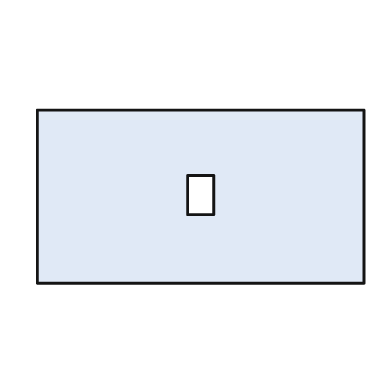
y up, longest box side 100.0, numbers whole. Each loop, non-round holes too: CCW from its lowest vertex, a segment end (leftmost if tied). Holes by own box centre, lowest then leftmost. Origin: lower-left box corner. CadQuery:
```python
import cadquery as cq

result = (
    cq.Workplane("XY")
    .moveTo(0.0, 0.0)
    .lineTo(100.0, 0.0)
    .lineTo(100.0, 53.0)
    .lineTo(0.0, 53.0)
    .close()
    .moveTo(46.0, 21.0)
    .lineTo(54.0, 21.0)
    .lineTo(54.0, 33.0)
    .lineTo(46.0, 33.0)
    .close()
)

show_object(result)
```